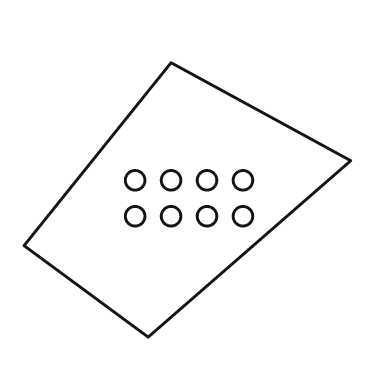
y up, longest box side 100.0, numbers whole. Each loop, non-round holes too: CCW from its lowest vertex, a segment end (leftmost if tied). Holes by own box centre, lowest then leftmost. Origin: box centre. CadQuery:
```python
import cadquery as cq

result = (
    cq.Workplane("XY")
    .moveTo(-12.0, -42.0)
    .lineTo(50.0, 12.0)
    .lineTo(-5.0, 42.0)
    .lineTo(-50.0, -14.0)
    .close()
    .moveTo(-16.0, -5.0)
    .circle(3.0)
    .moveTo(-5.0, -5.0)
    .circle(3.0)
    .moveTo(6.0, -5.0)
    .circle(3.0)
    .moveTo(17.0, -5.0)
    .circle(3.0)
    .moveTo(-16.0, 6.0)
    .circle(3.0)
    .moveTo(-5.0, 6.0)
    .circle(3.0)
    .moveTo(6.0, 6.0)
    .circle(3.0)
    .moveTo(17.0, 6.0)
    .circle(3.0)
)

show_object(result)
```